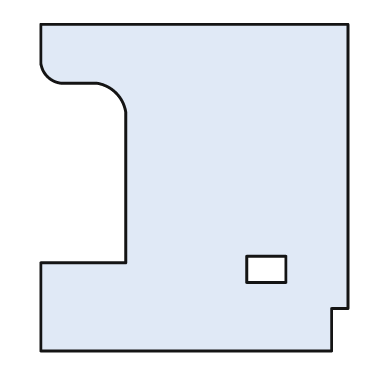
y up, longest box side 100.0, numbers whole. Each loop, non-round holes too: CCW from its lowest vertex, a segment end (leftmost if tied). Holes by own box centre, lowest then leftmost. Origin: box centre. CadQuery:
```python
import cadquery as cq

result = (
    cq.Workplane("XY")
    .moveTo(-47.0, -50.0)
    .lineTo(42.0, -50.0)
    .lineTo(42.0, -37.0)
    .lineTo(47.0, -37.0)
    .lineTo(47.0, 50.0)
    .lineTo(-47.0, 50.0)
    .lineTo(-47.0, 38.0)
    .threePointArc((-45.0, 34.0), (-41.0, 32.0))
    .lineTo(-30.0, 32.0)
    .threePointArc((-24.0, 29.0), (-21.0, 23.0))
    .lineTo(-21.0, -23.0)
    .lineTo(-47.0, -23.0)
    .close()
    .moveTo(16.0, -29.0)
    .lineTo(28.0, -29.0)
    .lineTo(28.0, -21.0)
    .lineTo(16.0, -21.0)
    .close()
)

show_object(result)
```